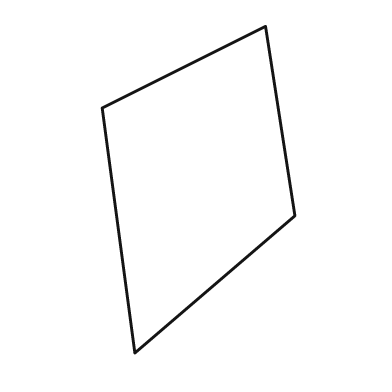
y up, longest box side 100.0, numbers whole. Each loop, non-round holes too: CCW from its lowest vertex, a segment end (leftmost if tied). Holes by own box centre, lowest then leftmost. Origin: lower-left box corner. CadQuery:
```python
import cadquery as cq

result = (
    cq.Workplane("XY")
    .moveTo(10.0, 0.0)
    .lineTo(59.0, 42.0)
    .lineTo(50.0, 100.0)
    .lineTo(0.0, 75.0)
    .close()
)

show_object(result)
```